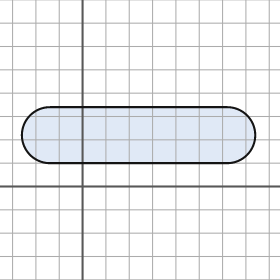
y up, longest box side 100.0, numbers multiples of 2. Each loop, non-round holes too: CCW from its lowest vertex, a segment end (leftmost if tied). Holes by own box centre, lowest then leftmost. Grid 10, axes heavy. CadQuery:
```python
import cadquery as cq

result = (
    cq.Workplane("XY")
    .moveTo(-14.0, 10.0)
    .lineTo(62.0, 10.0)
    .threePointArc((74.0, 22.0), (62.0, 34.0))
    .lineTo(-14.0, 34.0)
    .threePointArc((-26.0, 22.0), (-14.0, 10.0))
    .close()
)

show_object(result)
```